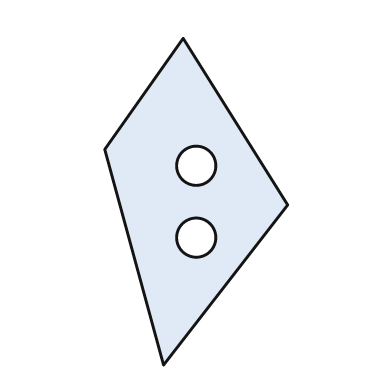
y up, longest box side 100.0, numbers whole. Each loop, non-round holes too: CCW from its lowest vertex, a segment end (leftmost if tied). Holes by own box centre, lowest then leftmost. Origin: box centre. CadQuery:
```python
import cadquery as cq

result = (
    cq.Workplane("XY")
    .moveTo(-10.0, -50.0)
    .lineTo(28.0, -1.0)
    .lineTo(-4.0, 50.0)
    .lineTo(-28.0, 16.0)
    .close()
    .moveTo(0.0, -11.0)
    .circle(6.0)
    .moveTo(0.0, 11.0)
    .circle(6.0)
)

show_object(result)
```